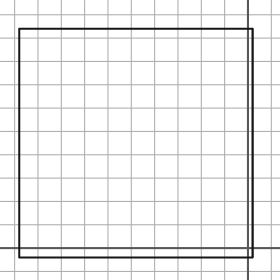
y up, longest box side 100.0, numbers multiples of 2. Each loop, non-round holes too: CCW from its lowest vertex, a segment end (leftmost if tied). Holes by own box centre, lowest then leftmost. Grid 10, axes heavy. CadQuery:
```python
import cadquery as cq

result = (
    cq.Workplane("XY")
    .moveTo(-98.0, -4.0)
    .lineTo(2.0, -4.0)
    .lineTo(2.0, 94.0)
    .lineTo(-98.0, 94.0)
    .close()
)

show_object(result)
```